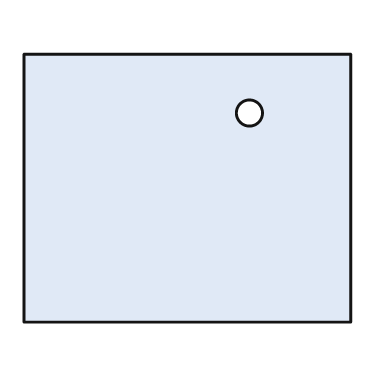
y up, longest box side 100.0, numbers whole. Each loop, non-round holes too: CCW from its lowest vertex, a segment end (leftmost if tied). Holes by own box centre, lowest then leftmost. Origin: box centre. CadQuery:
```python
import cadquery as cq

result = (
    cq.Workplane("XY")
    .moveTo(-50.0, -41.0)
    .lineTo(50.0, -41.0)
    .lineTo(50.0, 41.0)
    .lineTo(-50.0, 41.0)
    .close()
    .moveTo(19.0, 23.0)
    .circle(4.0)
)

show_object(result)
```